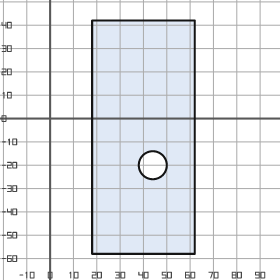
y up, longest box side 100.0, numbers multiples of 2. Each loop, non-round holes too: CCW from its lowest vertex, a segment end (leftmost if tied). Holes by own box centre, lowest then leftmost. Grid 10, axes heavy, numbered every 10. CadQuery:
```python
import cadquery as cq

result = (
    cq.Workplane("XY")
    .moveTo(18.0, -58.0)
    .lineTo(62.0, -58.0)
    .lineTo(62.0, 42.0)
    .lineTo(18.0, 42.0)
    .close()
    .moveTo(44.0, -20.0)
    .circle(6.0)
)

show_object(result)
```